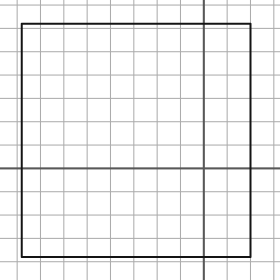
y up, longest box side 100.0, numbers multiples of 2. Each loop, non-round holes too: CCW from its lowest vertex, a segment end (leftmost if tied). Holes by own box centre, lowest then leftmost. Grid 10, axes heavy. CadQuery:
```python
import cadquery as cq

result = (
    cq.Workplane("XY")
    .moveTo(-78.0, -38.0)
    .lineTo(20.0, -38.0)
    .lineTo(20.0, 62.0)
    .lineTo(-78.0, 62.0)
    .close()
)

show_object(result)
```